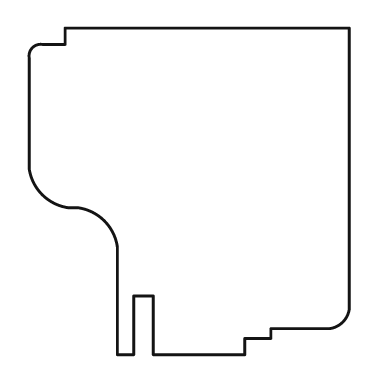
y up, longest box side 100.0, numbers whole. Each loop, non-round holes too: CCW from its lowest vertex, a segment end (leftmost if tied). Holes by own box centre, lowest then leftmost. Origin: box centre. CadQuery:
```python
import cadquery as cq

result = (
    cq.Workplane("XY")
    .moveTo(-22.0, -50.0)
    .lineTo(-17.0, -50.0)
    .lineTo(-17.0, -32.0)
    .lineTo(-11.0, -32.0)
    .lineTo(-11.0, -50.0)
    .lineTo(17.0, -50.0)
    .lineTo(17.0, -45.0)
    .lineTo(25.0, -45.0)
    .lineTo(25.0, -42.0)
    .lineTo(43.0, -42.0)
    .threePointArc((47.0, -40.0), (49.0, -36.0))
    .lineTo(49.0, 50.0)
    .lineTo(-38.0, 50.0)
    .lineTo(-38.0, 45.0)
    .lineTo(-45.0, 45.0)
    .threePointArc((-48.0, 44.0), (-49.0, 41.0))
    .lineTo(-49.0, 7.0)
    .threePointArc((-45.0, -1.0), (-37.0, -5.0))
    .lineTo(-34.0, -5.0)
    .threePointArc((-26.0, -9.0), (-22.0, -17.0))
    .close()
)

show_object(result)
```